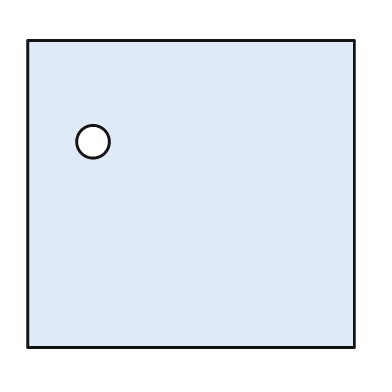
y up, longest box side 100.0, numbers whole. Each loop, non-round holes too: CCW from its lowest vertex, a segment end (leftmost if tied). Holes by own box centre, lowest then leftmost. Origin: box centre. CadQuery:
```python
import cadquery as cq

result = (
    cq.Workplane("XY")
    .moveTo(-50.0, -47.0)
    .lineTo(50.0, -47.0)
    .lineTo(50.0, 47.0)
    .lineTo(-50.0, 47.0)
    .close()
    .moveTo(-30.0, 16.0)
    .circle(5.0)
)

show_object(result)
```